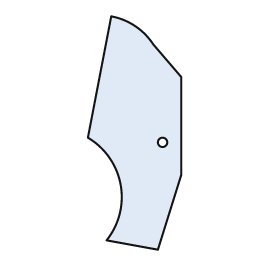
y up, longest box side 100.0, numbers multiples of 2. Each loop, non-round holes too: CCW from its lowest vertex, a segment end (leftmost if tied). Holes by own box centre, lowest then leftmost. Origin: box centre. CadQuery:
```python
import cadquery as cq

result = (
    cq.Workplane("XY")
    .moveTo(10.0, -50.0)
    .lineTo(20.0, -18.0)
    .lineTo(20.0, 24.0)
    .lineTo(8.0, 38.0)
    .threePointArc((0.0, 46.0), (-10.0, 50.0))
    .lineTo(-20.0, -2.0)
    .threePointArc((-6.0, -22.0), (-12.0, -46.0))
    .close()
    .moveTo(12.0, -4.0)
    .circle(2.0)
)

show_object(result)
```